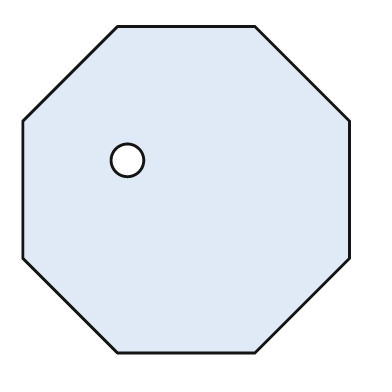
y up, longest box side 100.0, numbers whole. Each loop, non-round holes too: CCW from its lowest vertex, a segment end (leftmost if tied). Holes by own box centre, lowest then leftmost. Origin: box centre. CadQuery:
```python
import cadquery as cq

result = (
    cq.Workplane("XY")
    .moveTo(-21.0, -50.0)
    .lineTo(21.0, -50.0)
    .lineTo(50.0, -21.0)
    .lineTo(50.0, 21.0)
    .lineTo(21.0, 50.0)
    .lineTo(-21.0, 50.0)
    .lineTo(-50.0, 21.0)
    .lineTo(-50.0, -21.0)
    .close()
    .moveTo(-18.0, 9.0)
    .circle(5.0)
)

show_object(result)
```